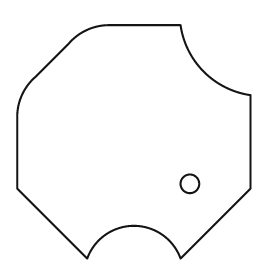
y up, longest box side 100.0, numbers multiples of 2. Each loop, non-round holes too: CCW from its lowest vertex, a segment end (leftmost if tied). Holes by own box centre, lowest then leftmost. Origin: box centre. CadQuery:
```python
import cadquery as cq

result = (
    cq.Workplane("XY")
    .moveTo(-20.0, -50.0)
    .threePointArc((0.0, -36.0), (20.0, -50.0))
    .lineTo(50.0, -20.0)
    .lineTo(50.0, 20.0)
    .threePointArc((30.0, 30.0), (20.0, 50.0))
    .lineTo(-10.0, 50.0)
    .threePointArc((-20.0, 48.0), (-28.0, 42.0))
    .lineTo(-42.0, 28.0)
    .threePointArc((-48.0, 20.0), (-50.0, 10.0))
    .lineTo(-50.0, -20.0)
    .close()
    .moveTo(24.0, -18.0)
    .circle(4.0)
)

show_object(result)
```